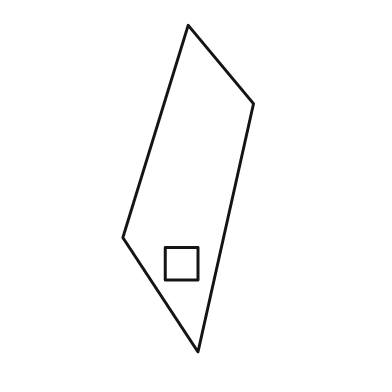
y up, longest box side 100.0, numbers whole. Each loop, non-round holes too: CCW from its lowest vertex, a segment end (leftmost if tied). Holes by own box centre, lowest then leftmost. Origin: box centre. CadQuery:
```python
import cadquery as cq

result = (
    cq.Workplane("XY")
    .moveTo(3.0, -50.0)
    .lineTo(20.0, 26.0)
    .lineTo(0.0, 50.0)
    .lineTo(-20.0, -15.0)
    .close()
    .moveTo(-7.0, -28.0)
    .lineTo(3.0, -28.0)
    .lineTo(3.0, -18.0)
    .lineTo(-7.0, -18.0)
    .close()
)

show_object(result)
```